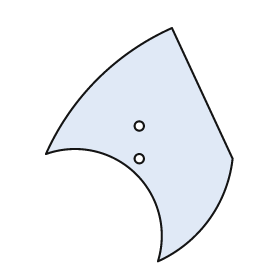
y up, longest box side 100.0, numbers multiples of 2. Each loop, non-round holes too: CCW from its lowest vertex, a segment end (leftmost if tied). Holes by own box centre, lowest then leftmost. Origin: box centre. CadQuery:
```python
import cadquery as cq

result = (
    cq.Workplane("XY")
    .moveTo(8.0, -50.0)
    .threePointArc((30.0, -32.0), (40.0, -6.0))
    .lineTo(14.0, 50.0)
    .threePointArc((-18.0, 28.0), (-40.0, -4.0))
    .threePointArc((-2.0, -12.0), (8.0, -50.0))
    .close()
    .moveTo(0.0, -6.0)
    .circle(2.0)
    .moveTo(0.0, 8.0)
    .circle(2.0)
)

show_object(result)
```